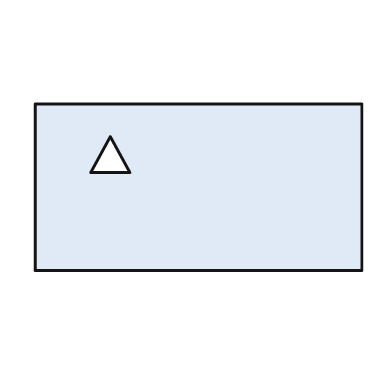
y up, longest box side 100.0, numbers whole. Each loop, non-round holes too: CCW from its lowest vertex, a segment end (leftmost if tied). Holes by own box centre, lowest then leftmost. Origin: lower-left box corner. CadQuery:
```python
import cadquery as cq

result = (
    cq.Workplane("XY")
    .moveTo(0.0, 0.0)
    .lineTo(100.0, 0.0)
    .lineTo(100.0, 51.0)
    .lineTo(0.0, 51.0)
    .close()
    .moveTo(17.0, 30.0)
    .lineTo(29.0, 30.0)
    .lineTo(23.0, 41.0)
    .close()
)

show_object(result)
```